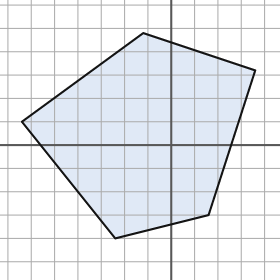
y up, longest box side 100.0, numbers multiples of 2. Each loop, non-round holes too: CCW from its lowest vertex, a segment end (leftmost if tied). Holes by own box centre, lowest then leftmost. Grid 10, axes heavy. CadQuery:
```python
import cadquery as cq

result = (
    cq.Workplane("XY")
    .moveTo(-24.0, -40.0)
    .lineTo(16.0, -30.0)
    .lineTo(36.0, 32.0)
    .lineTo(-12.0, 48.0)
    .lineTo(-64.0, 10.0)
    .close()
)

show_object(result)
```